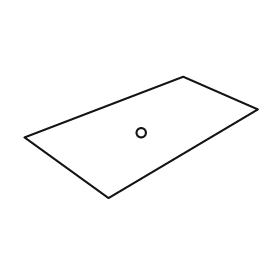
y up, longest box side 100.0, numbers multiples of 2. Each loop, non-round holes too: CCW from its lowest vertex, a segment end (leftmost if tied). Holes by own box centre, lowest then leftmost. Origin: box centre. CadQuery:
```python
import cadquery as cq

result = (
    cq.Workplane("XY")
    .moveTo(-14.0, -26.0)
    .lineTo(50.0, 12.0)
    .lineTo(18.0, 26.0)
    .lineTo(-50.0, 0.0)
    .close()
    .moveTo(0.0, 2.0)
    .circle(2.0)
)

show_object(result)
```